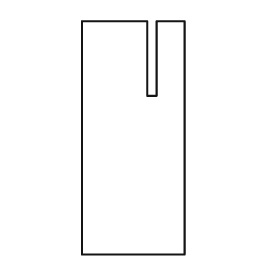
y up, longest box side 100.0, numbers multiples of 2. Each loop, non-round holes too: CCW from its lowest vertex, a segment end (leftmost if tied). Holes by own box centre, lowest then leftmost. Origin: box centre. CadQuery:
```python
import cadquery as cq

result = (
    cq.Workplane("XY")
    .moveTo(-22.0, -50.0)
    .lineTo(22.0, -50.0)
    .lineTo(22.0, 50.0)
    .lineTo(10.0, 50.0)
    .lineTo(10.0, 18.0)
    .lineTo(6.0, 18.0)
    .lineTo(6.0, 50.0)
    .lineTo(-22.0, 50.0)
    .close()
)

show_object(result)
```